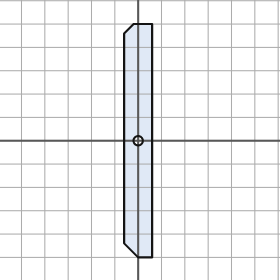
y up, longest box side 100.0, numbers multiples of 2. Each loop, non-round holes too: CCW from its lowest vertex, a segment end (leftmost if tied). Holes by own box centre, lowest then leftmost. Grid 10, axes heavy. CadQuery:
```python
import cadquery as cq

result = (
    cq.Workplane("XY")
    .moveTo(0.0, -50.0)
    .lineTo(6.0, -50.0)
    .lineTo(6.0, 50.0)
    .lineTo(-2.0, 50.0)
    .lineTo(-6.0, 46.0)
    .lineTo(-6.0, -44.0)
    .close()
    .moveTo(0.0, 0.0)
    .circle(2.0)
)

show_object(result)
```